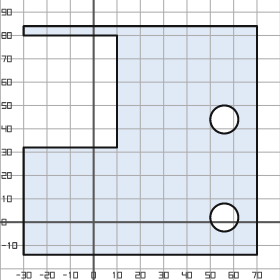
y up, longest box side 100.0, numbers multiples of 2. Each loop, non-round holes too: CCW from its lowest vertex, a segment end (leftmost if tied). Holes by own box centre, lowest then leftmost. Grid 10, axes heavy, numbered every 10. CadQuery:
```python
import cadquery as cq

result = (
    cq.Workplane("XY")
    .moveTo(-30.0, -14.0)
    .lineTo(70.0, -14.0)
    .lineTo(70.0, 84.0)
    .lineTo(-30.0, 84.0)
    .lineTo(-30.0, 80.0)
    .lineTo(10.0, 80.0)
    .lineTo(10.0, 32.0)
    .lineTo(-30.0, 32.0)
    .close()
    .moveTo(56.0, 2.0)
    .circle(6.0)
    .moveTo(56.0, 44.0)
    .circle(6.0)
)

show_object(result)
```